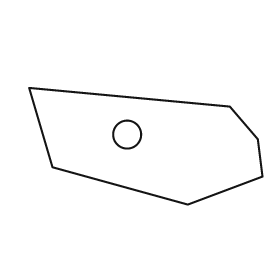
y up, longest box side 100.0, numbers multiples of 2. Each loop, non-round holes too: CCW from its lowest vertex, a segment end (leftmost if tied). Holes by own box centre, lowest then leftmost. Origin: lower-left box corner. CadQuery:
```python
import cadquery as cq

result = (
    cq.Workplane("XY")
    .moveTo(68.0, 0.0)
    .lineTo(100.0, 12.0)
    .lineTo(98.0, 28.0)
    .lineTo(86.0, 42.0)
    .lineTo(0.0, 50.0)
    .lineTo(10.0, 16.0)
    .close()
    .moveTo(42.0, 30.0)
    .circle(6.0)
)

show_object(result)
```